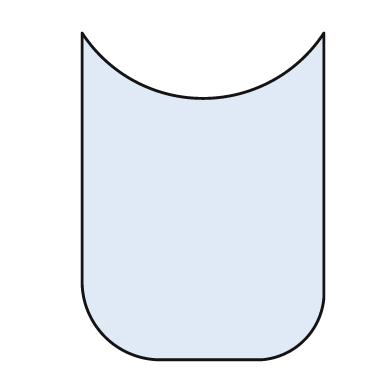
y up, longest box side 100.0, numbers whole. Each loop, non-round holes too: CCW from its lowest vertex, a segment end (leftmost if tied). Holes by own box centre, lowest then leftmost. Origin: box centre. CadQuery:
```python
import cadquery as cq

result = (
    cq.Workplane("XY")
    .moveTo(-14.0, -50.0)
    .lineTo(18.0, -50.0)
    .threePointArc((31.0, -44.0), (37.0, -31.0))
    .lineTo(37.0, 50.0)
    .threePointArc((0.0, 30.0), (-37.0, 50.0))
    .lineTo(-37.0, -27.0)
    .threePointArc((-30.0, -43.0), (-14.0, -50.0))
    .close()
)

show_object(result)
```